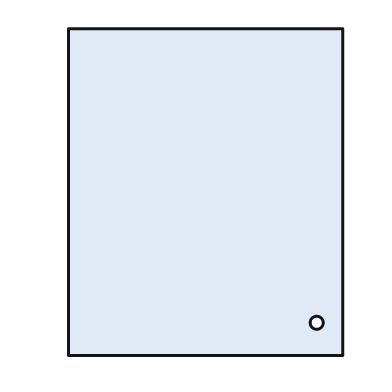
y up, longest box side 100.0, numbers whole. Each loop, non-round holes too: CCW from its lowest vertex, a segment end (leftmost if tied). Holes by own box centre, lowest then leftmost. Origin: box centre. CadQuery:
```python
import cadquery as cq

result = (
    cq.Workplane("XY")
    .moveTo(-42.0, -50.0)
    .lineTo(42.0, -50.0)
    .lineTo(42.0, 50.0)
    .lineTo(-42.0, 50.0)
    .close()
    .moveTo(34.0, -40.0)
    .circle(2.0)
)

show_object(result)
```